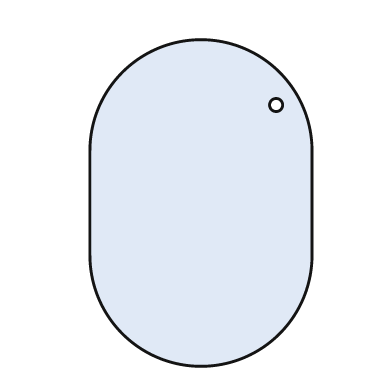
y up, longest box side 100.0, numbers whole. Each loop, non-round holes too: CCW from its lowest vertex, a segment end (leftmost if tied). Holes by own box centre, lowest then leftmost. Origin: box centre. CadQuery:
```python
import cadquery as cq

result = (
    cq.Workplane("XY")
    .moveTo(-34.0, -16.0)
    .threePointArc((0.0, -50.0), (34.0, -16.0))
    .lineTo(34.0, 16.0)
    .threePointArc((0.0, 50.0), (-34.0, 16.0))
    .close()
    .moveTo(23.0, 30.0)
    .circle(2.0)
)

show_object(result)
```